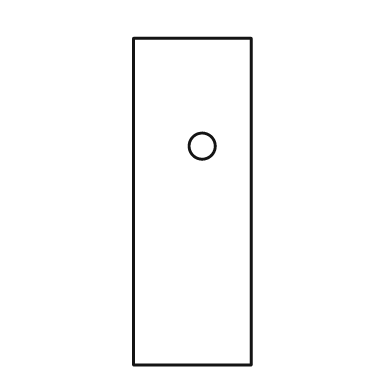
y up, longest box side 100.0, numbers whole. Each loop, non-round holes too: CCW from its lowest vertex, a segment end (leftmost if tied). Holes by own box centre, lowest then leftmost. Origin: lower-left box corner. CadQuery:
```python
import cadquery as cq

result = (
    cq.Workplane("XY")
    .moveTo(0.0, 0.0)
    .lineTo(36.0, 0.0)
    .lineTo(36.0, 100.0)
    .lineTo(0.0, 100.0)
    .close()
    .moveTo(21.0, 67.0)
    .circle(4.0)
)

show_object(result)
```